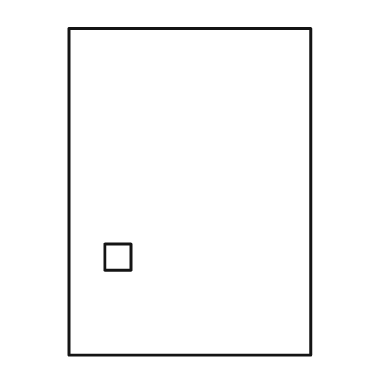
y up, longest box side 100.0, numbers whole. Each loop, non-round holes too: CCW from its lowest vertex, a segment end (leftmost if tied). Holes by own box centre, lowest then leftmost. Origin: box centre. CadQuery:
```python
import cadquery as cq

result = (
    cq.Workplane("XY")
    .moveTo(-37.0, -50.0)
    .lineTo(37.0, -50.0)
    .lineTo(37.0, 50.0)
    .lineTo(-37.0, 50.0)
    .close()
    .moveTo(-26.0, -24.0)
    .lineTo(-18.0, -24.0)
    .lineTo(-18.0, -16.0)
    .lineTo(-26.0, -16.0)
    .close()
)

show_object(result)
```